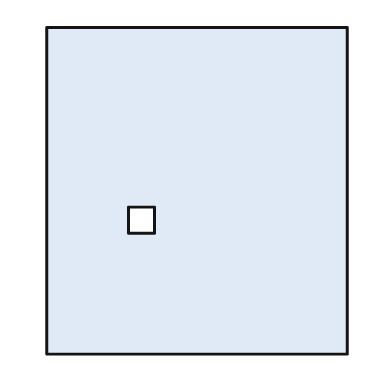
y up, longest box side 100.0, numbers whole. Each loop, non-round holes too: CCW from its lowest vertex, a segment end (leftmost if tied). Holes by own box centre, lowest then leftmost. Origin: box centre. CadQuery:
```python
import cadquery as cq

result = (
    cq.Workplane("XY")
    .moveTo(-46.0, -50.0)
    .lineTo(46.0, -50.0)
    .lineTo(46.0, 50.0)
    .lineTo(-46.0, 50.0)
    .close()
    .moveTo(-21.0, -13.0)
    .lineTo(-13.0, -13.0)
    .lineTo(-13.0, -5.0)
    .lineTo(-21.0, -5.0)
    .close()
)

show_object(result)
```